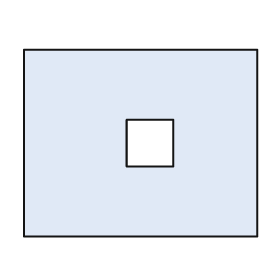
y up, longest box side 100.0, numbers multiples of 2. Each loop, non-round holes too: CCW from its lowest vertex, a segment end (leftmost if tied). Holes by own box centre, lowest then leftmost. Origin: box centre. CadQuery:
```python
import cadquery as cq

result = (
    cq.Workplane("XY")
    .moveTo(-50.0, -40.0)
    .lineTo(50.0, -40.0)
    .lineTo(50.0, 40.0)
    .lineTo(-50.0, 40.0)
    .close()
    .moveTo(-6.0, -10.0)
    .lineTo(14.0, -10.0)
    .lineTo(14.0, 10.0)
    .lineTo(-6.0, 10.0)
    .close()
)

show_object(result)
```